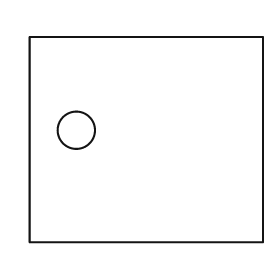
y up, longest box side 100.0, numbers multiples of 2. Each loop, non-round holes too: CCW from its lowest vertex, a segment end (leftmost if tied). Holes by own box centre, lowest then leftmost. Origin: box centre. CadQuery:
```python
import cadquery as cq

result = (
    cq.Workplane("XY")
    .moveTo(-50.0, -44.0)
    .lineTo(50.0, -44.0)
    .lineTo(50.0, 44.0)
    .lineTo(-50.0, 44.0)
    .close()
    .moveTo(-30.0, 4.0)
    .circle(8.0)
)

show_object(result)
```